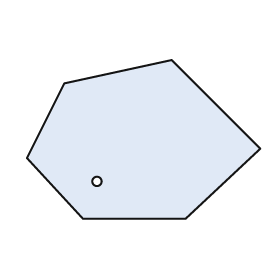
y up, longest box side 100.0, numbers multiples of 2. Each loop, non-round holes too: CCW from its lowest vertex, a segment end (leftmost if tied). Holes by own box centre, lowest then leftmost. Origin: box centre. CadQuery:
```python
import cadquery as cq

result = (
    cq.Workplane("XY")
    .moveTo(-26.0, -34.0)
    .lineTo(18.0, -34.0)
    .lineTo(50.0, -4.0)
    .lineTo(12.0, 34.0)
    .lineTo(-34.0, 24.0)
    .lineTo(-50.0, -8.0)
    .close()
    .moveTo(-20.0, -18.0)
    .circle(2.0)
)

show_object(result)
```